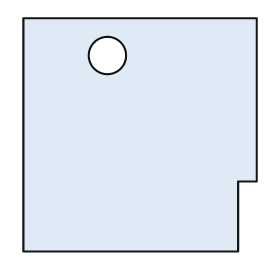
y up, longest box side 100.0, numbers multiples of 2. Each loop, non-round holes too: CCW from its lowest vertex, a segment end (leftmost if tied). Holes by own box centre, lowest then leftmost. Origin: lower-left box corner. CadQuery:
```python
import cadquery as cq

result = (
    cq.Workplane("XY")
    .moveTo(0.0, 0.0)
    .lineTo(92.0, 0.0)
    .lineTo(92.0, 30.0)
    .lineTo(100.0, 30.0)
    .lineTo(100.0, 100.0)
    .lineTo(0.0, 100.0)
    .close()
    .moveTo(36.0, 84.0)
    .circle(8.0)
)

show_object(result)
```